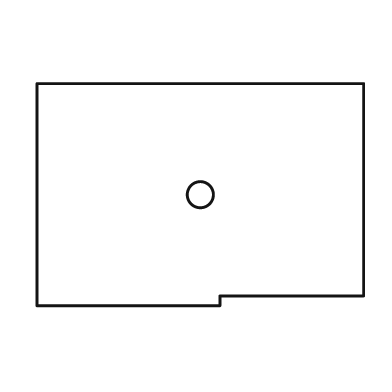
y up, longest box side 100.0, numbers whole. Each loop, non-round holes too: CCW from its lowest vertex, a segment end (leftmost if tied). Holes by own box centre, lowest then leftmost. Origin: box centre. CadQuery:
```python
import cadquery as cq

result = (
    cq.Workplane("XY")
    .moveTo(-50.0, -34.0)
    .lineTo(6.0, -34.0)
    .lineTo(6.0, -31.0)
    .lineTo(50.0, -31.0)
    .lineTo(50.0, 34.0)
    .lineTo(-50.0, 34.0)
    .close()
    .moveTo(0.0, 0.0)
    .circle(4.0)
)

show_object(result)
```